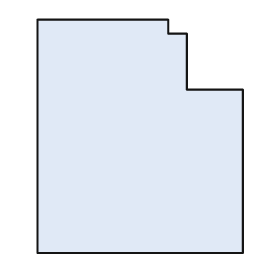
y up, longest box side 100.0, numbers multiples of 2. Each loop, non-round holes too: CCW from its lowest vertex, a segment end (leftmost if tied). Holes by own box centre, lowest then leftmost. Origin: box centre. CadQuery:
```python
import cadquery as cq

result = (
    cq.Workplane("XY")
    .moveTo(-44.0, -50.0)
    .lineTo(44.0, -50.0)
    .lineTo(44.0, 20.0)
    .lineTo(20.0, 20.0)
    .lineTo(20.0, 44.0)
    .lineTo(12.0, 44.0)
    .lineTo(12.0, 50.0)
    .lineTo(-44.0, 50.0)
    .close()
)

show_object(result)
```